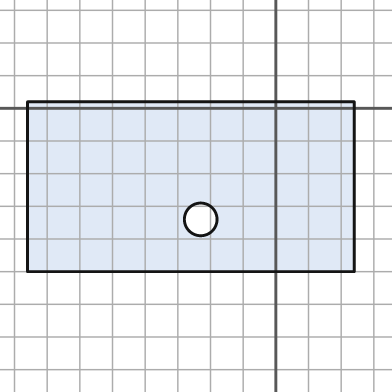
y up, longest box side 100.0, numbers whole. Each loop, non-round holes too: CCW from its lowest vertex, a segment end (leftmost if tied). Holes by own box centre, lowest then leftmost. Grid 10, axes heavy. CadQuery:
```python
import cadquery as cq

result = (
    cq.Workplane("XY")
    .moveTo(-76.0, -50.0)
    .lineTo(24.0, -50.0)
    .lineTo(24.0, 2.0)
    .lineTo(-76.0, 2.0)
    .close()
    .moveTo(-23.0, -34.0)
    .circle(5.0)
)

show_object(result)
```